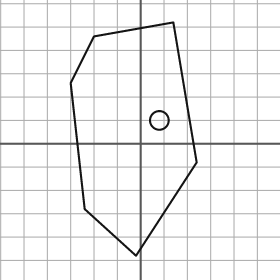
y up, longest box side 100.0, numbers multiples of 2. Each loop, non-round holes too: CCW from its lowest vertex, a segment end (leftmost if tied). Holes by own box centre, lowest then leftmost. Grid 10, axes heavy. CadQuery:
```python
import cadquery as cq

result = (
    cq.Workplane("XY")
    .moveTo(-2.0, -48.0)
    .lineTo(24.0, -8.0)
    .lineTo(14.0, 52.0)
    .lineTo(-20.0, 46.0)
    .lineTo(-30.0, 26.0)
    .lineTo(-24.0, -28.0)
    .close()
    .moveTo(8.0, 10.0)
    .circle(4.0)
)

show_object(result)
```